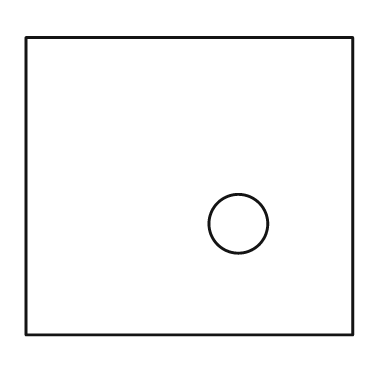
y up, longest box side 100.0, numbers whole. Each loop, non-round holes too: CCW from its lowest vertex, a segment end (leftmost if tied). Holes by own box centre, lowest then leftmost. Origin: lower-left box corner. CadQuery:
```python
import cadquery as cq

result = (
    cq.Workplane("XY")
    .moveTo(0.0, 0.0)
    .lineTo(100.0, 0.0)
    .lineTo(100.0, 91.0)
    .lineTo(0.0, 91.0)
    .close()
    .moveTo(65.0, 34.0)
    .circle(9.0)
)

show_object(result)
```